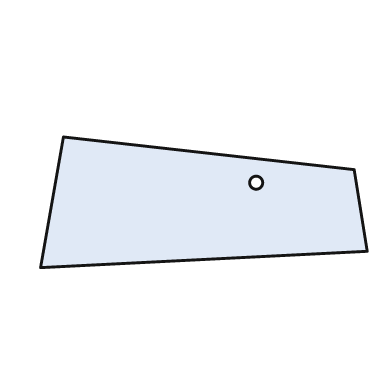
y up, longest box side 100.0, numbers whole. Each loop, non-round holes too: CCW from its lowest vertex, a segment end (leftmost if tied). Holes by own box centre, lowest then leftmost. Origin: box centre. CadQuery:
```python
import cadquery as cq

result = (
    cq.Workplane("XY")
    .moveTo(-50.0, -20.0)
    .lineTo(50.0, -15.0)
    .lineTo(46.0, 10.0)
    .lineTo(-43.0, 20.0)
    .close()
    .moveTo(16.0, 6.0)
    .circle(2.0)
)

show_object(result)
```